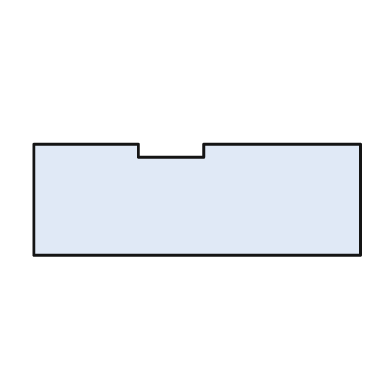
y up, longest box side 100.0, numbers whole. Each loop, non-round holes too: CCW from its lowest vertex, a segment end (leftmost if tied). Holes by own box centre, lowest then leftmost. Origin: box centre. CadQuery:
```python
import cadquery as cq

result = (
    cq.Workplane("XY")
    .moveTo(-50.0, -17.0)
    .lineTo(50.0, -17.0)
    .lineTo(50.0, 17.0)
    .lineTo(2.0, 17.0)
    .lineTo(2.0, 13.0)
    .lineTo(-18.0, 13.0)
    .lineTo(-18.0, 17.0)
    .lineTo(-50.0, 17.0)
    .close()
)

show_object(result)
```